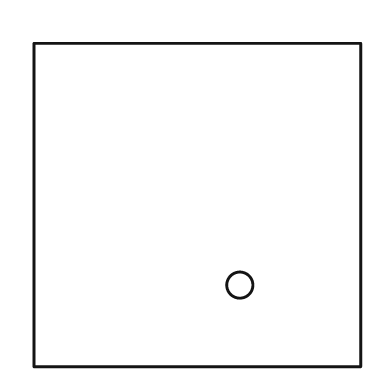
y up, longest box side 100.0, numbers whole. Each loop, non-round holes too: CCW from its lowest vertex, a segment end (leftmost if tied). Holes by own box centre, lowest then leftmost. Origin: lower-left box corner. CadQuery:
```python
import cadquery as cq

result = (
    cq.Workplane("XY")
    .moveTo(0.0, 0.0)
    .lineTo(100.0, 0.0)
    .lineTo(100.0, 99.0)
    .lineTo(0.0, 99.0)
    .close()
    .moveTo(63.0, 25.0)
    .circle(4.0)
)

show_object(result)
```